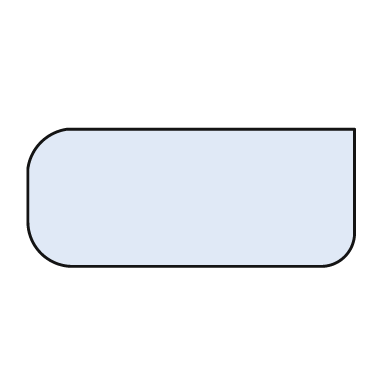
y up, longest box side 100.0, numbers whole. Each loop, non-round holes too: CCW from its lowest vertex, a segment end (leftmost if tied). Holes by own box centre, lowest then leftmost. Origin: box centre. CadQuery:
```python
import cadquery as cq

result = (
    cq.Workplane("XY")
    .moveTo(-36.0, -21.0)
    .lineTo(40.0, -21.0)
    .threePointArc((47.0, -18.0), (50.0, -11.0))
    .lineTo(50.0, 21.0)
    .lineTo(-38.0, 21.0)
    .threePointArc((-46.0, 17.0), (-50.0, 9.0))
    .lineTo(-50.0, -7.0)
    .threePointArc((-46.0, -17.0), (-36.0, -21.0))
    .close()
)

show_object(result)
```